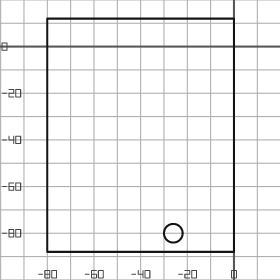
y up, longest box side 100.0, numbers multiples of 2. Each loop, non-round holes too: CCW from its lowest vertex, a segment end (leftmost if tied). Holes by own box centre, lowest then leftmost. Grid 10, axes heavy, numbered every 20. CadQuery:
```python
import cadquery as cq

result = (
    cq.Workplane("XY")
    .moveTo(-80.0, -88.0)
    .lineTo(0.0, -88.0)
    .lineTo(0.0, 12.0)
    .lineTo(-80.0, 12.0)
    .close()
    .moveTo(-26.0, -80.0)
    .circle(4.0)
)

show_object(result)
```